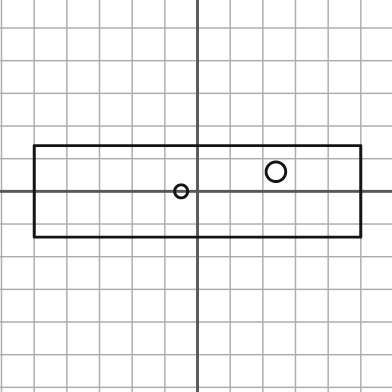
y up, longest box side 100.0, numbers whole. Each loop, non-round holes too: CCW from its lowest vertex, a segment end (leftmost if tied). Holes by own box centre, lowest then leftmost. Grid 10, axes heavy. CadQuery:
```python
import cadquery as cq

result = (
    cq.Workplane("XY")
    .moveTo(-50.0, -14.0)
    .lineTo(50.0, -14.0)
    .lineTo(50.0, 14.0)
    .lineTo(-50.0, 14.0)
    .close()
    .moveTo(-5.0, 0.0)
    .circle(2.0)
    .moveTo(24.0, 6.0)
    .circle(3.0)
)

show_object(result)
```